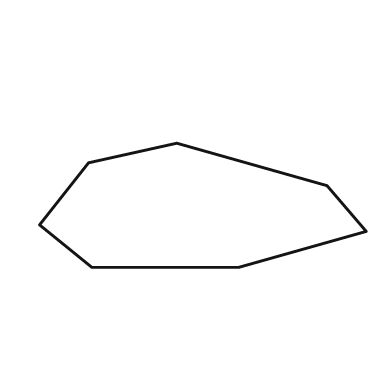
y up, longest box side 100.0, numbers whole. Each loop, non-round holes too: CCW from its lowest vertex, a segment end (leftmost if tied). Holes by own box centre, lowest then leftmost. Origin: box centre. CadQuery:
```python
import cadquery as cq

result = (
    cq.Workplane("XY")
    .moveTo(-34.0, -19.0)
    .lineTo(11.0, -19.0)
    .lineTo(50.0, -8.0)
    .lineTo(38.0, 6.0)
    .lineTo(-8.0, 19.0)
    .lineTo(-35.0, 13.0)
    .lineTo(-50.0, -6.0)
    .close()
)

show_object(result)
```